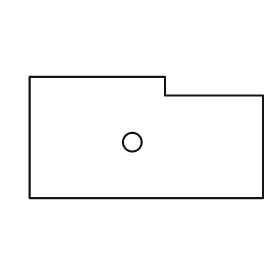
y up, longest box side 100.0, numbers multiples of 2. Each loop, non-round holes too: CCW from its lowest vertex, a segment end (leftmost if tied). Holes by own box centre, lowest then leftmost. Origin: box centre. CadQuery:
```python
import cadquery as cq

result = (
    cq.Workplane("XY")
    .moveTo(-50.0, -26.0)
    .lineTo(50.0, -26.0)
    .lineTo(50.0, 18.0)
    .lineTo(8.0, 18.0)
    .lineTo(8.0, 26.0)
    .lineTo(-50.0, 26.0)
    .close()
    .moveTo(-6.0, -2.0)
    .circle(4.0)
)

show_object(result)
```